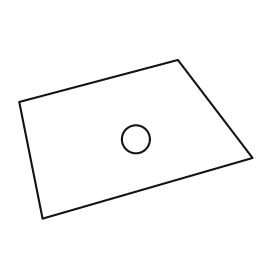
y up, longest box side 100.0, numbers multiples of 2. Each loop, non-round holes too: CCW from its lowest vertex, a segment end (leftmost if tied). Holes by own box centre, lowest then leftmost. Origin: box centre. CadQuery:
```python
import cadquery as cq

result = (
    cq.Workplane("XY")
    .moveTo(-40.0, -34.0)
    .lineTo(50.0, -8.0)
    .lineTo(18.0, 34.0)
    .lineTo(-50.0, 16.0)
    .close()
    .moveTo(0.0, 0.0)
    .circle(6.0)
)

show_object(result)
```